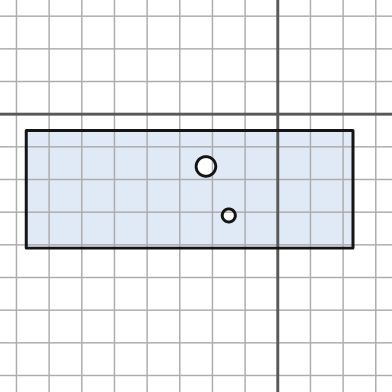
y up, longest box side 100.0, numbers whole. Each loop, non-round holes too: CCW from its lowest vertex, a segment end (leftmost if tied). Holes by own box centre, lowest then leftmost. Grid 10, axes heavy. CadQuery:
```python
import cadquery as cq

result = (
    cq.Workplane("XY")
    .moveTo(-77.0, -41.0)
    .lineTo(23.0, -41.0)
    .lineTo(23.0, -5.0)
    .lineTo(-77.0, -5.0)
    .close()
    .moveTo(-15.0, -31.0)
    .circle(2.0)
    .moveTo(-22.0, -16.0)
    .circle(3.0)
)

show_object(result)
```